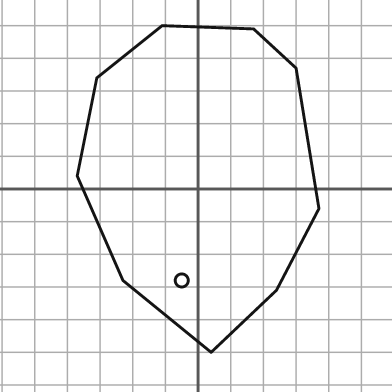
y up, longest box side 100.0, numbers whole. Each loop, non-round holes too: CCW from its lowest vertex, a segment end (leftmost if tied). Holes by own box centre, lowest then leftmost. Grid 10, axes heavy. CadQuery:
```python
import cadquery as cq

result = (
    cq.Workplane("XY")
    .moveTo(4.0, -50.0)
    .lineTo(24.0, -31.0)
    .lineTo(37.0, -6.0)
    .lineTo(30.0, 37.0)
    .lineTo(17.0, 49.0)
    .lineTo(-11.0, 50.0)
    .lineTo(-31.0, 34.0)
    .lineTo(-37.0, 4.0)
    .lineTo(-23.0, -28.0)
    .close()
    .moveTo(-5.0, -28.0)
    .circle(2.0)
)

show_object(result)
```